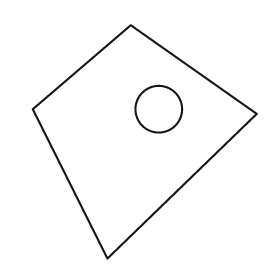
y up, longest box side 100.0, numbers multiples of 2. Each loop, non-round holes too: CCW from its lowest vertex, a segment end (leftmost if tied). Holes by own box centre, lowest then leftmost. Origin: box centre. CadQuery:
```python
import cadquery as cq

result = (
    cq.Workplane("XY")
    .moveTo(-16.0, -50.0)
    .lineTo(48.0, 12.0)
    .lineTo(-6.0, 50.0)
    .lineTo(-48.0, 14.0)
    .close()
    .moveTo(6.0, 14.0)
    .circle(10.0)
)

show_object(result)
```